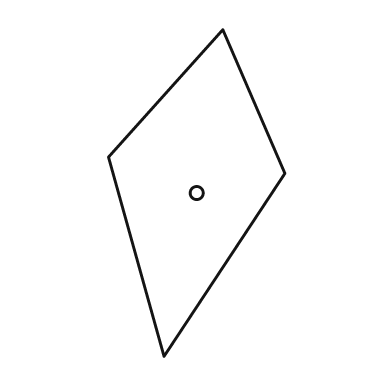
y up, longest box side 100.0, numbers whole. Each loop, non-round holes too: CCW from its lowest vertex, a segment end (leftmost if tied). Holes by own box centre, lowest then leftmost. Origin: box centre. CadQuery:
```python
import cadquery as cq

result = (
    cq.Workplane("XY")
    .moveTo(-10.0, -50.0)
    .lineTo(27.0, 6.0)
    .lineTo(8.0, 50.0)
    .lineTo(-27.0, 11.0)
    .close()
    .moveTo(0.0, 0.0)
    .circle(2.0)
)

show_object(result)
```